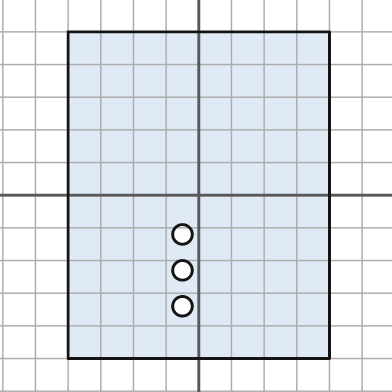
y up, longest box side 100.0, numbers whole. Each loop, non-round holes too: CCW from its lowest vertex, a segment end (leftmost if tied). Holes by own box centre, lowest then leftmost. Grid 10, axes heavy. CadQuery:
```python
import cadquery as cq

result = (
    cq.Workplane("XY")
    .moveTo(-40.0, -50.0)
    .lineTo(40.0, -50.0)
    .lineTo(40.0, 50.0)
    .lineTo(-40.0, 50.0)
    .close()
    .moveTo(-5.0, -34.0)
    .circle(3.0)
    .moveTo(-5.0, -23.0)
    .circle(3.0)
    .moveTo(-5.0, -12.0)
    .circle(3.0)
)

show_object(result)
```